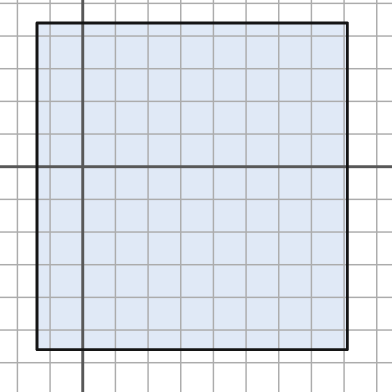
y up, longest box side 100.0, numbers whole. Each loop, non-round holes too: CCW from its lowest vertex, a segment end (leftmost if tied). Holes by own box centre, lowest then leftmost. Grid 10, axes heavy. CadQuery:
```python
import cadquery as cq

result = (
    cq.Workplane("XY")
    .moveTo(-14.0, -56.0)
    .lineTo(81.0, -56.0)
    .lineTo(81.0, 44.0)
    .lineTo(-14.0, 44.0)
    .close()
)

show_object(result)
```